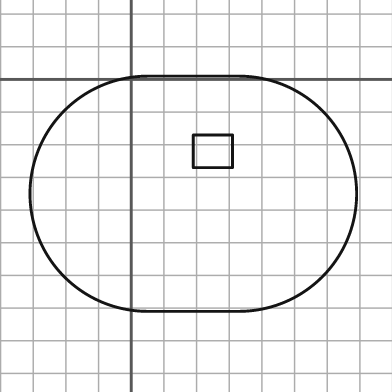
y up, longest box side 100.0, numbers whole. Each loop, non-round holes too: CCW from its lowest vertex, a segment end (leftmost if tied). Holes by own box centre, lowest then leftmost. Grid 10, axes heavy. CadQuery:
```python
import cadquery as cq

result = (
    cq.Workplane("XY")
    .moveTo(5.0, -71.0)
    .lineTo(33.0, -71.0)
    .threePointArc((69.0, -35.0), (33.0, 1.0))
    .lineTo(5.0, 1.0)
    .threePointArc((-31.0, -35.0), (5.0, -71.0))
    .close()
    .moveTo(19.0, -27.0)
    .lineTo(31.0, -27.0)
    .lineTo(31.0, -17.0)
    .lineTo(19.0, -17.0)
    .close()
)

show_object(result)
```